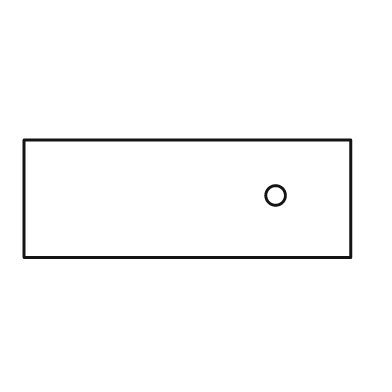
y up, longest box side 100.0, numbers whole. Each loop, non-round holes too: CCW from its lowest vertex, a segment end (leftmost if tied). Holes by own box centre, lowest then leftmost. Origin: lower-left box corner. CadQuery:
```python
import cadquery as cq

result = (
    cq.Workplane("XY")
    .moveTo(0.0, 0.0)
    .lineTo(100.0, 0.0)
    .lineTo(100.0, 36.0)
    .lineTo(0.0, 36.0)
    .close()
    .moveTo(77.0, 19.0)
    .circle(3.0)
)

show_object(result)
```